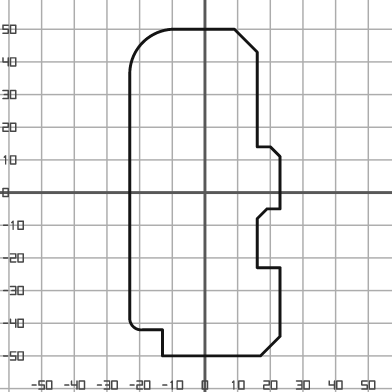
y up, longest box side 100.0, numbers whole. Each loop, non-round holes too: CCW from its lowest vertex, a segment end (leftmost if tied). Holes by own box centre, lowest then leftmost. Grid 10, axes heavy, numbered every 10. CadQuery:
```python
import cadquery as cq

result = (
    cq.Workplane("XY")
    .moveTo(-13.0, -50.0)
    .lineTo(17.0, -50.0)
    .lineTo(23.0, -44.0)
    .lineTo(23.0, -23.0)
    .lineTo(16.0, -23.0)
    .lineTo(16.0, -8.0)
    .lineTo(19.0, -5.0)
    .lineTo(23.0, -5.0)
    .lineTo(23.0, 11.0)
    .lineTo(20.0, 14.0)
    .lineTo(16.0, 14.0)
    .lineTo(16.0, 43.0)
    .lineTo(9.0, 50.0)
    .lineTo(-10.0, 50.0)
    .threePointArc((-19.0, 46.0), (-23.0, 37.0))
    .lineTo(-23.0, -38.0)
    .threePointArc((-22.0, -41.0), (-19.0, -42.0))
    .lineTo(-13.0, -42.0)
    .close()
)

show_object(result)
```